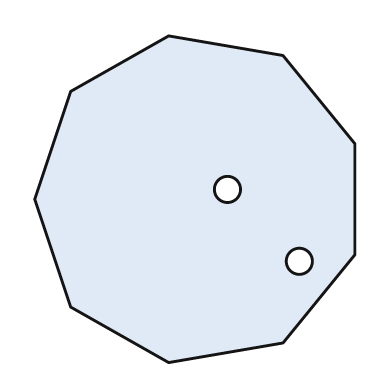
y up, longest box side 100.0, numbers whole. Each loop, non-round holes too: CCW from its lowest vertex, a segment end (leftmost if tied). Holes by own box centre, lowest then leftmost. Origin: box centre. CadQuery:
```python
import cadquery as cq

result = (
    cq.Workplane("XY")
    .moveTo(-8.0, -50.0)
    .lineTo(27.0, -44.0)
    .lineTo(49.0, -17.0)
    .lineTo(49.0, 17.0)
    .lineTo(27.0, 44.0)
    .lineTo(-8.0, 50.0)
    .lineTo(-38.0, 33.0)
    .lineTo(-49.0, 0.0)
    .lineTo(-38.0, -33.0)
    .close()
    .moveTo(32.0, -19.0)
    .circle(4.0)
    .moveTo(10.0, 3.0)
    .circle(4.0)
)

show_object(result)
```